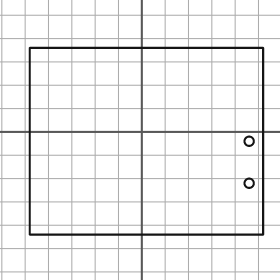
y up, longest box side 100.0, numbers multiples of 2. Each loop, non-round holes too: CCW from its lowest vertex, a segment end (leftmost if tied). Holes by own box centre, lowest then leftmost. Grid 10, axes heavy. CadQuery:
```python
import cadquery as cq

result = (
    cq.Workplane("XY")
    .moveTo(-48.0, -44.0)
    .lineTo(52.0, -44.0)
    .lineTo(52.0, 36.0)
    .lineTo(-48.0, 36.0)
    .close()
    .moveTo(46.0, -22.0)
    .circle(2.0)
    .moveTo(46.0, -4.0)
    .circle(2.0)
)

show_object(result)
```